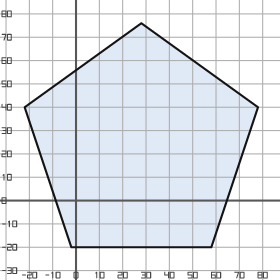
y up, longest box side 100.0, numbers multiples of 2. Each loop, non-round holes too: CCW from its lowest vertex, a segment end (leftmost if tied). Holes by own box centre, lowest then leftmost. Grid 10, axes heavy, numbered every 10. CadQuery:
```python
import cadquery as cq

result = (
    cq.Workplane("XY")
    .moveTo(-2.0, -20.0)
    .lineTo(58.0, -20.0)
    .lineTo(78.0, 40.0)
    .lineTo(28.0, 76.0)
    .lineTo(-22.0, 40.0)
    .close()
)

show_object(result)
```